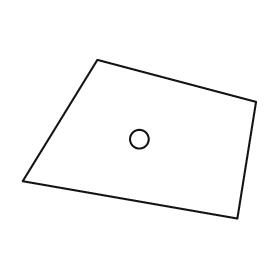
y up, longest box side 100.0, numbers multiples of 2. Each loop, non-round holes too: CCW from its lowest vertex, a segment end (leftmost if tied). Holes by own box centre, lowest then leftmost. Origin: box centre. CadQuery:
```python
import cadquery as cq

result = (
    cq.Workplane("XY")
    .moveTo(42.0, -34.0)
    .lineTo(50.0, 16.0)
    .lineTo(-18.0, 34.0)
    .lineTo(-50.0, -18.0)
    .close()
    .moveTo(0.0, 0.0)
    .circle(4.0)
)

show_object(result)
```